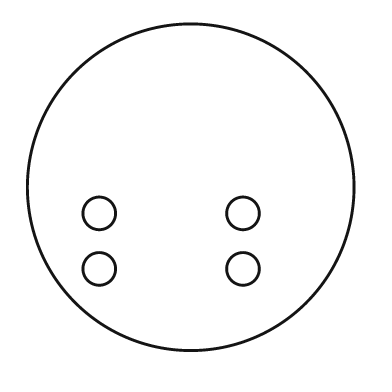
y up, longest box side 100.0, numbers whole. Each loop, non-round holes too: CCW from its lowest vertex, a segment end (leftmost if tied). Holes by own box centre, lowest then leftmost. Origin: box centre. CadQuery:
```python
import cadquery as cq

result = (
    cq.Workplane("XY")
    .moveTo(0.0, 0.0)
    .circle(50.0)
    .moveTo(-28.0, -25.0)
    .circle(5.0)
    .moveTo(16.0, -25.0)
    .circle(5.0)
    .moveTo(-28.0, -8.0)
    .circle(5.0)
    .moveTo(16.0, -8.0)
    .circle(5.0)
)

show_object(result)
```